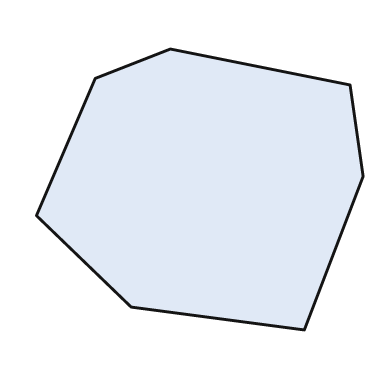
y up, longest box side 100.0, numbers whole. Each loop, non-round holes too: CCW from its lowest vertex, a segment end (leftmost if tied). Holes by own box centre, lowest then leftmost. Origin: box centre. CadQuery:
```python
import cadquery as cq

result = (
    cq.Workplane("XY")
    .moveTo(32.0, -43.0)
    .lineTo(50.0, 4.0)
    .lineTo(46.0, 32.0)
    .lineTo(-9.0, 43.0)
    .lineTo(-32.0, 34.0)
    .lineTo(-50.0, -8.0)
    .lineTo(-21.0, -36.0)
    .close()
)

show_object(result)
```